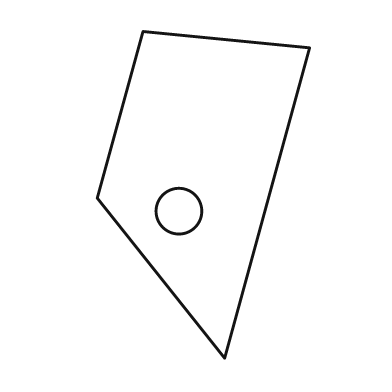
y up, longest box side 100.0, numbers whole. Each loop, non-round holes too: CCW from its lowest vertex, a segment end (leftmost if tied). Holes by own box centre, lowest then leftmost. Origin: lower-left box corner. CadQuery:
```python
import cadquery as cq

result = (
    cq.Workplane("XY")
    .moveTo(39.0, 0.0)
    .lineTo(65.0, 95.0)
    .lineTo(14.0, 100.0)
    .lineTo(0.0, 49.0)
    .close()
    .moveTo(25.0, 45.0)
    .circle(7.0)
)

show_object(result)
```